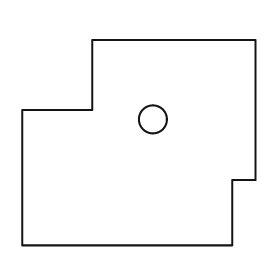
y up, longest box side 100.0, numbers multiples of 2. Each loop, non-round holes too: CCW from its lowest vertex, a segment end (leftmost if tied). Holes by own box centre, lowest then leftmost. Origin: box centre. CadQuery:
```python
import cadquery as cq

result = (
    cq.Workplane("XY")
    .moveTo(-50.0, -44.0)
    .lineTo(40.0, -44.0)
    .lineTo(40.0, -16.0)
    .lineTo(50.0, -16.0)
    .lineTo(50.0, 44.0)
    .lineTo(-20.0, 44.0)
    .lineTo(-20.0, 14.0)
    .lineTo(-50.0, 14.0)
    .close()
    .moveTo(6.0, 10.0)
    .circle(6.0)
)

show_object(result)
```